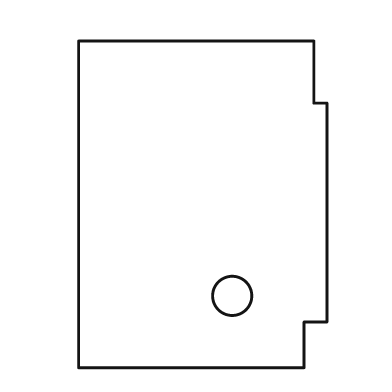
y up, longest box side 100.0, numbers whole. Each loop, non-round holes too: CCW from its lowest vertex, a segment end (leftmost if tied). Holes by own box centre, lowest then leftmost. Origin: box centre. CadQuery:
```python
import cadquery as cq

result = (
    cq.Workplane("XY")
    .moveTo(-38.0, -50.0)
    .lineTo(31.0, -50.0)
    .lineTo(31.0, -36.0)
    .lineTo(38.0, -36.0)
    .lineTo(38.0, 31.0)
    .lineTo(34.0, 31.0)
    .lineTo(34.0, 50.0)
    .lineTo(-38.0, 50.0)
    .close()
    .moveTo(9.0, -28.0)
    .circle(6.0)
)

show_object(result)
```